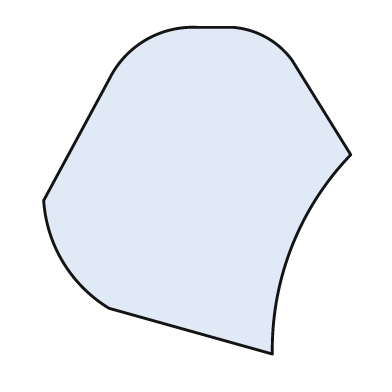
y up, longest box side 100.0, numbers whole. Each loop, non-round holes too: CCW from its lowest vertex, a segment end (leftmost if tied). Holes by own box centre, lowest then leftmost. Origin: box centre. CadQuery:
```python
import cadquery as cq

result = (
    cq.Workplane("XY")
    .moveTo(23.0, -50.0)
    .threePointArc((29.0, -17.0), (47.0, 11.0))
    .lineTo(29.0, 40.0)
    .threePointArc((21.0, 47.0), (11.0, 50.0))
    .lineTo(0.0, 50.0)
    .threePointArc((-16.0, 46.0), (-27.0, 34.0))
    .lineTo(-47.0, -3.0)
    .threePointArc((-41.0, -22.0), (-27.0, -36.0))
    .close()
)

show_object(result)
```